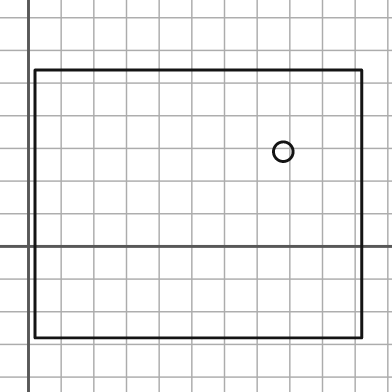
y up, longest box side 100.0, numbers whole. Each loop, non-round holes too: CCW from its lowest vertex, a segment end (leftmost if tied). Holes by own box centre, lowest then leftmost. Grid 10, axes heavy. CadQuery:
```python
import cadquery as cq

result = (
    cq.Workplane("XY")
    .moveTo(2.0, -28.0)
    .lineTo(102.0, -28.0)
    .lineTo(102.0, 54.0)
    .lineTo(2.0, 54.0)
    .close()
    .moveTo(78.0, 29.0)
    .circle(3.0)
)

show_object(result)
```